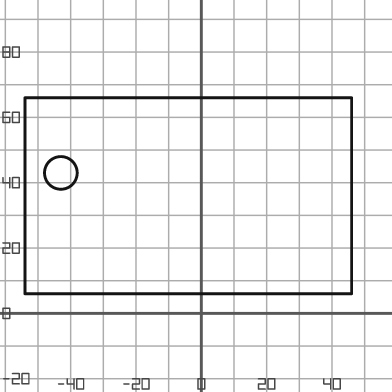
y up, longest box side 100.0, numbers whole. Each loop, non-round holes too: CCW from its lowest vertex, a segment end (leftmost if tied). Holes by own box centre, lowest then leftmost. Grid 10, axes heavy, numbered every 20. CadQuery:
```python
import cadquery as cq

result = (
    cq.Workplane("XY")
    .moveTo(-54.0, 6.0)
    .lineTo(46.0, 6.0)
    .lineTo(46.0, 66.0)
    .lineTo(-54.0, 66.0)
    .close()
    .moveTo(-43.0, 43.0)
    .circle(5.0)
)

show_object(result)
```